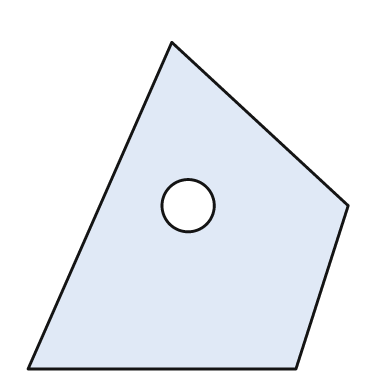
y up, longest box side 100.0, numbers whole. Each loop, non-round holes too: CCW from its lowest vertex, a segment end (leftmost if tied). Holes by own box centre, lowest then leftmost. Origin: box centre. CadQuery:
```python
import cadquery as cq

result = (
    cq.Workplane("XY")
    .moveTo(-49.0, -50.0)
    .lineTo(33.0, -50.0)
    .lineTo(49.0, 0.0)
    .lineTo(-5.0, 50.0)
    .close()
    .moveTo(0.0, 0.0)
    .circle(8.0)
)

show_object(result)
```